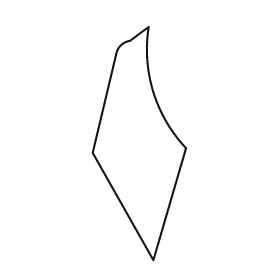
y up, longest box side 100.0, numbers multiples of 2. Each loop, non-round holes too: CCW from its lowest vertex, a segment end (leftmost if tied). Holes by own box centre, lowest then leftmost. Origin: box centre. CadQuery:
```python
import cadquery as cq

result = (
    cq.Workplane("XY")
    .moveTo(6.0, -50.0)
    .lineTo(20.0, -2.0)
    .threePointArc((6.0, 22.0), (4.0, 50.0))
    .lineTo(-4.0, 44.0)
    .threePointArc((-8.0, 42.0), (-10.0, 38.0))
    .lineTo(-20.0, -4.0)
    .close()
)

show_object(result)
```